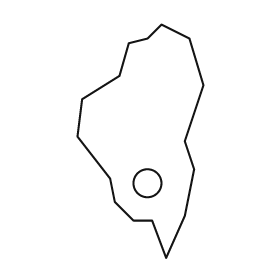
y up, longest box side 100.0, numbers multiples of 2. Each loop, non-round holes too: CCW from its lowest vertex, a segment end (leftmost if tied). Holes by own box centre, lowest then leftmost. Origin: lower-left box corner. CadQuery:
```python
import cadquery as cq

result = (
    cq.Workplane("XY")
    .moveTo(38.0, 0.0)
    .lineTo(46.0, 18.0)
    .lineTo(50.0, 38.0)
    .lineTo(46.0, 50.0)
    .lineTo(54.0, 74.0)
    .lineTo(48.0, 94.0)
    .lineTo(36.0, 100.0)
    .lineTo(30.0, 94.0)
    .lineTo(22.0, 92.0)
    .lineTo(18.0, 78.0)
    .lineTo(2.0, 68.0)
    .lineTo(0.0, 52.0)
    .lineTo(14.0, 34.0)
    .lineTo(16.0, 24.0)
    .lineTo(24.0, 16.0)
    .lineTo(32.0, 16.0)
    .close()
    .moveTo(30.0, 32.0)
    .circle(6.0)
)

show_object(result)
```